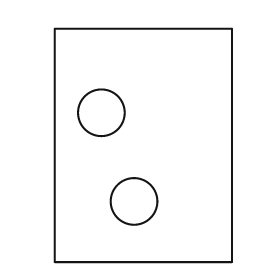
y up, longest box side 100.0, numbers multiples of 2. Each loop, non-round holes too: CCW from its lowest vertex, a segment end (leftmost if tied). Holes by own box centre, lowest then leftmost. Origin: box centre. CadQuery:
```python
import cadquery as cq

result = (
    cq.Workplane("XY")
    .moveTo(-38.0, -50.0)
    .lineTo(38.0, -50.0)
    .lineTo(38.0, 50.0)
    .lineTo(-38.0, 50.0)
    .close()
    .moveTo(-4.0, -24.0)
    .circle(10.0)
    .moveTo(-18.0, 14.0)
    .circle(10.0)
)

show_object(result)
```